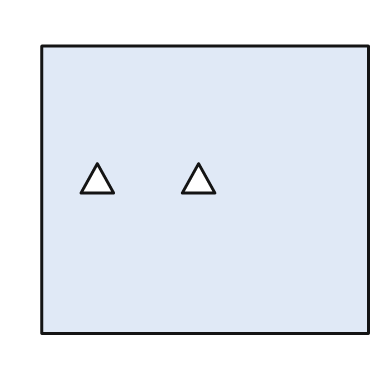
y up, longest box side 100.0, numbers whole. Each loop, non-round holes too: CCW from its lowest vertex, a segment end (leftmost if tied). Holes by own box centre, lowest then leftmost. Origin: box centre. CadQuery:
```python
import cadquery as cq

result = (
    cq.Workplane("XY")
    .moveTo(-50.0, -44.0)
    .lineTo(50.0, -44.0)
    .lineTo(50.0, 44.0)
    .lineTo(-50.0, 44.0)
    .close()
    .moveTo(-38.0, -1.0)
    .lineTo(-28.0, -1.0)
    .lineTo(-33.0, 8.0)
    .close()
    .moveTo(-7.0, -1.0)
    .lineTo(3.0, -1.0)
    .lineTo(-2.0, 8.0)
    .close()
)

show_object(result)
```